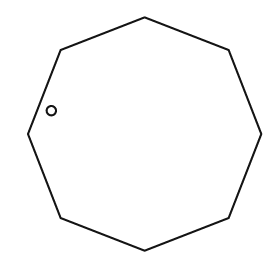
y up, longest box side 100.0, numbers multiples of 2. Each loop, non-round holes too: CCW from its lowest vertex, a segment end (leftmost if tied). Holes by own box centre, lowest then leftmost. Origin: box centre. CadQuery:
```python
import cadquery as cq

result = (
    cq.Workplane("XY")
    .moveTo(0.0, -50.0)
    .lineTo(36.0, -36.0)
    .lineTo(50.0, 0.0)
    .lineTo(36.0, 36.0)
    .lineTo(0.0, 50.0)
    .lineTo(-36.0, 36.0)
    .lineTo(-50.0, 0.0)
    .lineTo(-36.0, -36.0)
    .close()
    .moveTo(-40.0, 10.0)
    .circle(2.0)
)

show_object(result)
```